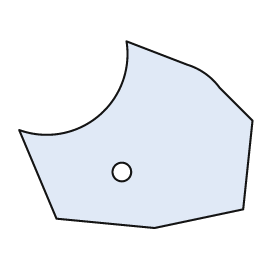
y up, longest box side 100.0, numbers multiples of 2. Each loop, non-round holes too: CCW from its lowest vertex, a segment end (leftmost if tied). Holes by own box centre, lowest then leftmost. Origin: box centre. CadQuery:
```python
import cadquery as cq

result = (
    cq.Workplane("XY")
    .moveTo(8.0, -40.0)
    .lineTo(46.0, -32.0)
    .lineTo(50.0, 6.0)
    .lineTo(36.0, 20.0)
    .threePointArc((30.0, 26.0), (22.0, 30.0))
    .lineTo(-4.0, 40.0)
    .threePointArc((-16.0, 8.0), (-50.0, 2.0))
    .lineTo(-34.0, -36.0)
    .close()
    .moveTo(-6.0, -16.0)
    .circle(4.0)
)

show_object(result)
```